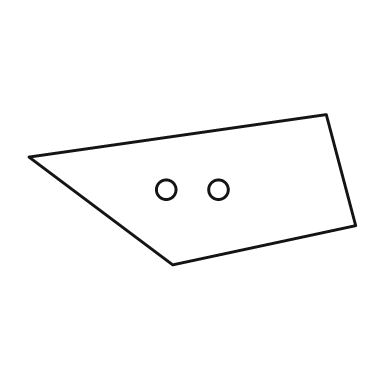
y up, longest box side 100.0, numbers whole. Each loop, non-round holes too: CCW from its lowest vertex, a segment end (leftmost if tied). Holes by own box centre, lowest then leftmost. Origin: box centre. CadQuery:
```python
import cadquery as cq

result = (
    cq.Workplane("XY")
    .moveTo(-6.0, -23.0)
    .lineTo(50.0, -11.0)
    .lineTo(41.0, 23.0)
    .lineTo(-50.0, 10.0)
    .close()
    .moveTo(-8.0, 0.0)
    .circle(3.0)
    .moveTo(8.0, 0.0)
    .circle(3.0)
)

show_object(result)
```